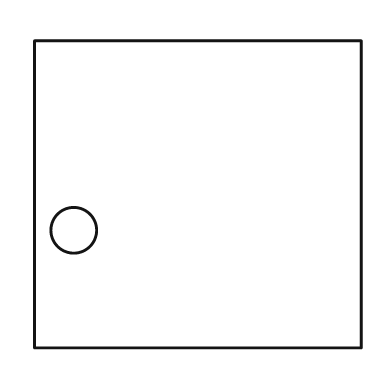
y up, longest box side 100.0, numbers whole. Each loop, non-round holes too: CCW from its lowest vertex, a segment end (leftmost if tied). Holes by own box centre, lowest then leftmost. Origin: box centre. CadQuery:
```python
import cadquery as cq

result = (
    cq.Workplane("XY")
    .moveTo(-50.0, -47.0)
    .lineTo(50.0, -47.0)
    .lineTo(50.0, 47.0)
    .lineTo(-50.0, 47.0)
    .close()
    .moveTo(-38.0, -11.0)
    .circle(7.0)
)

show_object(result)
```